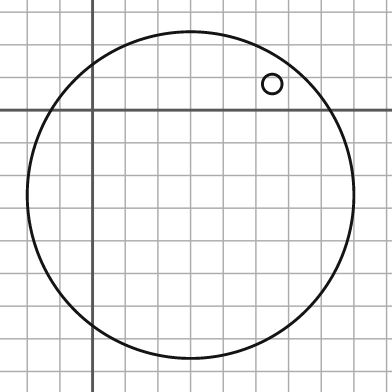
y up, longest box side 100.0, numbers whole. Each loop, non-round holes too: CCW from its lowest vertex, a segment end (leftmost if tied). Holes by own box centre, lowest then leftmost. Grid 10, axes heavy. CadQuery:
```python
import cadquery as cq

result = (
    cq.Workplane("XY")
    .moveTo(30.0, -26.0)
    .circle(50.0)
    .moveTo(55.0, 8.0)
    .circle(3.0)
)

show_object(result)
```